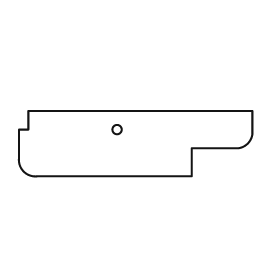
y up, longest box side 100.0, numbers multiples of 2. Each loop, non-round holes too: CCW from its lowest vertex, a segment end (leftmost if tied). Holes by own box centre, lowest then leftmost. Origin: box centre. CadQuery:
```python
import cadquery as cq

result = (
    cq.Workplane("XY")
    .moveTo(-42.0, -14.0)
    .lineTo(24.0, -14.0)
    .lineTo(24.0, -2.0)
    .lineTo(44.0, -2.0)
    .threePointArc((48.0, 0.0), (50.0, 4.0))
    .lineTo(50.0, 14.0)
    .lineTo(-46.0, 14.0)
    .lineTo(-46.0, 6.0)
    .lineTo(-50.0, 6.0)
    .lineTo(-50.0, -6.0)
    .threePointArc((-48.0, -12.0), (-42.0, -14.0))
    .close()
    .moveTo(-8.0, 6.0)
    .circle(2.0)
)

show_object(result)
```